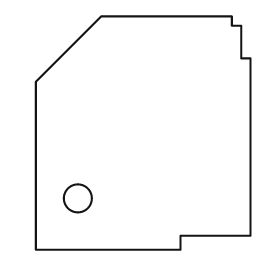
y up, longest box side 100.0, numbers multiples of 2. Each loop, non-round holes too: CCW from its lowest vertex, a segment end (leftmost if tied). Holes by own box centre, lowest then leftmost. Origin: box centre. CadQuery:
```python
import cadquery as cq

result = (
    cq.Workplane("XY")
    .moveTo(-46.0, -50.0)
    .lineTo(16.0, -50.0)
    .lineTo(16.0, -44.0)
    .lineTo(46.0, -44.0)
    .lineTo(46.0, 32.0)
    .lineTo(42.0, 32.0)
    .lineTo(42.0, 46.0)
    .lineTo(38.0, 46.0)
    .lineTo(38.0, 50.0)
    .lineTo(-18.0, 50.0)
    .lineTo(-46.0, 22.0)
    .close()
    .moveTo(-28.0, -28.0)
    .circle(6.0)
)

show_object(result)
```